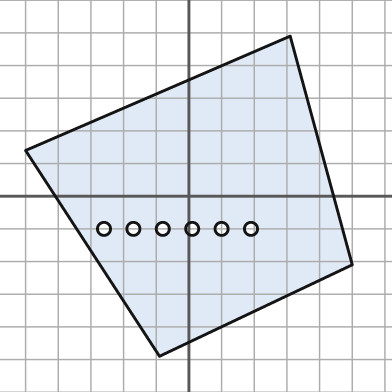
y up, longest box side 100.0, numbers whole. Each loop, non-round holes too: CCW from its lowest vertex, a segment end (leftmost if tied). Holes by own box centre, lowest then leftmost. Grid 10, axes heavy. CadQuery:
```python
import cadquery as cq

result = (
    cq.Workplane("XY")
    .moveTo(-9.0, -49.0)
    .lineTo(50.0, -21.0)
    .lineTo(31.0, 49.0)
    .lineTo(-50.0, 14.0)
    .close()
    .moveTo(-26.0, -10.0)
    .circle(2.0)
    .moveTo(-17.0, -10.0)
    .circle(2.0)
    .moveTo(-8.0, -10.0)
    .circle(2.0)
    .moveTo(1.0, -10.0)
    .circle(2.0)
    .moveTo(10.0, -10.0)
    .circle(2.0)
    .moveTo(19.0, -10.0)
    .circle(2.0)
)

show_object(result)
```